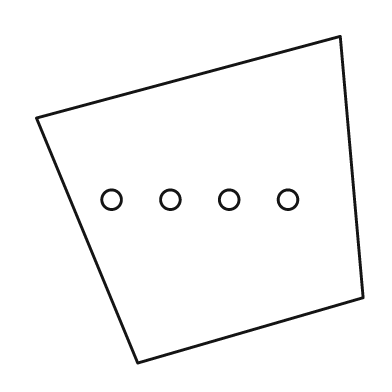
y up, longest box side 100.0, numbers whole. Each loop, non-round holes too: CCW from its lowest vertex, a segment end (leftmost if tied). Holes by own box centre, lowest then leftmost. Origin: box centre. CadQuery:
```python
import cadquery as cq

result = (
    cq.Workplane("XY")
    .moveTo(-19.0, -50.0)
    .lineTo(50.0, -30.0)
    .lineTo(43.0, 50.0)
    .lineTo(-50.0, 25.0)
    .close()
    .moveTo(-27.0, 0.0)
    .circle(3.0)
    .moveTo(-9.0, 0.0)
    .circle(3.0)
    .moveTo(9.0, 0.0)
    .circle(3.0)
    .moveTo(27.0, 0.0)
    .circle(3.0)
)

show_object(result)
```